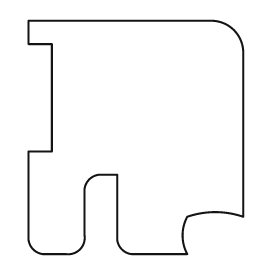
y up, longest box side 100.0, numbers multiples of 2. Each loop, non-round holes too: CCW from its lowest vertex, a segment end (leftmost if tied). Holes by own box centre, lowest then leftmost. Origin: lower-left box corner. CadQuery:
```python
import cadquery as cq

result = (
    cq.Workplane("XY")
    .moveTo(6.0, 0.0)
    .lineTo(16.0, 0.0)
    .threePointArc((22.0, 2.0), (24.0, 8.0))
    .lineTo(24.0, 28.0)
    .threePointArc((26.0, 32.0), (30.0, 34.0))
    .lineTo(38.0, 34.0)
    .lineTo(38.0, 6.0)
    .threePointArc((40.0, 2.0), (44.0, 0.0))
    .lineTo(68.0, 0.0)
    .threePointArc((66.0, 8.0), (68.0, 16.0))
    .threePointArc((80.0, 18.0), (92.0, 16.0))
    .lineTo(92.0, 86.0)
    .threePointArc((88.0, 96.0), (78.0, 100.0))
    .lineTo(0.0, 100.0)
    .lineTo(0.0, 90.0)
    .lineTo(10.0, 90.0)
    .lineTo(10.0, 44.0)
    .lineTo(0.0, 44.0)
    .lineTo(0.0, 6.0)
    .threePointArc((2.0, 2.0), (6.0, 0.0))
    .close()
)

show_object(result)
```